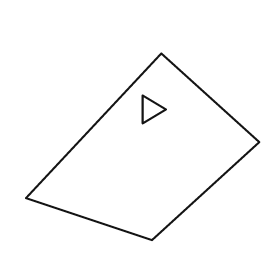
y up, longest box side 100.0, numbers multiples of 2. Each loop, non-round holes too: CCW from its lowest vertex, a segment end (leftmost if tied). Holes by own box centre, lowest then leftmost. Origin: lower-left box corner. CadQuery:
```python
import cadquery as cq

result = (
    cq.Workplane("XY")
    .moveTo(54.0, 0.0)
    .lineTo(100.0, 42.0)
    .lineTo(58.0, 80.0)
    .lineTo(0.0, 18.0)
    .close()
    .moveTo(50.0, 50.0)
    .lineTo(60.0, 56.0)
    .lineTo(50.0, 62.0)
    .close()
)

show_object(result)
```